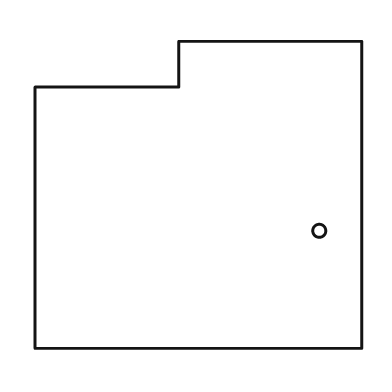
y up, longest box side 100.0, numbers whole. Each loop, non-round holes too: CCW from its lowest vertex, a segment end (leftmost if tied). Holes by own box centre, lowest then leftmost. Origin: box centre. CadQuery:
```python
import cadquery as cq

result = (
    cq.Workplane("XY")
    .moveTo(-50.0, -47.0)
    .lineTo(50.0, -47.0)
    .lineTo(50.0, 47.0)
    .lineTo(-6.0, 47.0)
    .lineTo(-6.0, 33.0)
    .lineTo(-50.0, 33.0)
    .close()
    .moveTo(37.0, -11.0)
    .circle(2.0)
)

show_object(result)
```